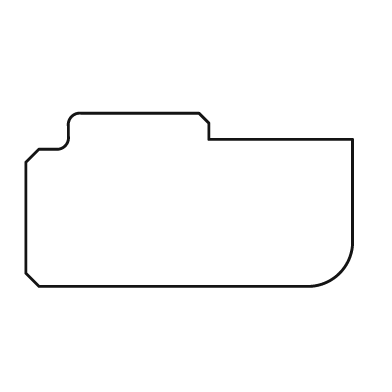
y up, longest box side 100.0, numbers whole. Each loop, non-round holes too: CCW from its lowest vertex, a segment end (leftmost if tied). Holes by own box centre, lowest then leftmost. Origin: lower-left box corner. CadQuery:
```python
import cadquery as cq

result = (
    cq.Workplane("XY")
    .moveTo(4.0, 0.0)
    .lineTo(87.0, 0.0)
    .threePointArc((96.0, 4.0), (100.0, 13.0))
    .lineTo(100.0, 45.0)
    .lineTo(56.0, 45.0)
    .lineTo(56.0, 50.0)
    .lineTo(53.0, 53.0)
    .lineTo(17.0, 53.0)
    .threePointArc((14.0, 52.0), (13.0, 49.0))
    .lineTo(13.0, 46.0)
    .threePointArc((12.0, 43.0), (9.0, 42.0))
    .lineTo(4.0, 42.0)
    .lineTo(0.0, 38.0)
    .lineTo(0.0, 4.0)
    .close()
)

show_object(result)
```